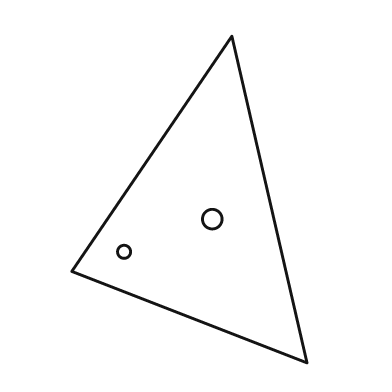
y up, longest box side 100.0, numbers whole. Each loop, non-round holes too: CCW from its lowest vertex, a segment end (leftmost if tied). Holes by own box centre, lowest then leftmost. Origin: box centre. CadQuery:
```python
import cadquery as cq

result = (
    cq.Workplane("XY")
    .moveTo(36.0, -50.0)
    .lineTo(13.0, 50.0)
    .lineTo(-36.0, -22.0)
    .close()
    .moveTo(-20.0, -16.0)
    .circle(2.0)
    .moveTo(7.0, -6.0)
    .circle(3.0)
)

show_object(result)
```